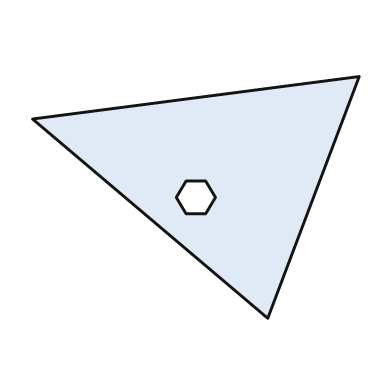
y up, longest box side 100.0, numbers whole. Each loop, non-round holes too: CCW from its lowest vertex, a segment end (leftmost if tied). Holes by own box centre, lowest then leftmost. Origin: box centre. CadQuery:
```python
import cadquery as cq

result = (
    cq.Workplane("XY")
    .moveTo(22.0, -37.0)
    .lineTo(50.0, 37.0)
    .lineTo(-50.0, 24.0)
    .close()
    .moveTo(-3.0, -5.0)
    .lineTo(3.0, -5.0)
    .lineTo(6.0, 0.0)
    .lineTo(3.0, 5.0)
    .lineTo(-3.0, 5.0)
    .lineTo(-6.0, 0.0)
    .close()
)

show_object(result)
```